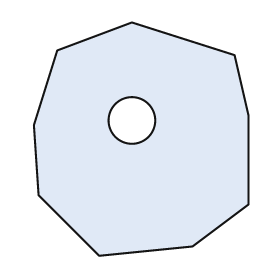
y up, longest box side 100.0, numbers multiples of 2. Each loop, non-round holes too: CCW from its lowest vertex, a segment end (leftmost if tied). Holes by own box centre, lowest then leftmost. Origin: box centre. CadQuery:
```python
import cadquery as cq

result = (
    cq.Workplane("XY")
    .moveTo(-18.0, -50.0)
    .lineTo(22.0, -46.0)
    .lineTo(46.0, -28.0)
    .lineTo(46.0, 10.0)
    .lineTo(40.0, 36.0)
    .lineTo(-4.0, 50.0)
    .lineTo(-36.0, 38.0)
    .lineTo(-46.0, 6.0)
    .lineTo(-44.0, -24.0)
    .close()
    .moveTo(-4.0, 8.0)
    .circle(10.0)
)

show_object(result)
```